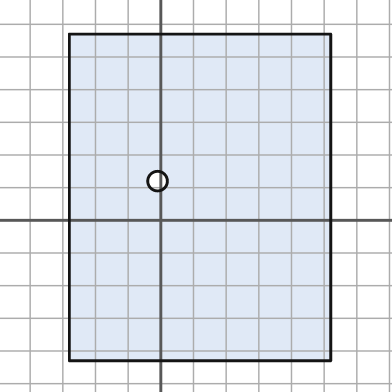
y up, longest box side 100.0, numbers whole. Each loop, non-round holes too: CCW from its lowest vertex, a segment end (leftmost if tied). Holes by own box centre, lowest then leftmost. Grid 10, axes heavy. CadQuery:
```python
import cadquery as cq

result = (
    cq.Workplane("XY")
    .moveTo(-28.0, -43.0)
    .lineTo(52.0, -43.0)
    .lineTo(52.0, 57.0)
    .lineTo(-28.0, 57.0)
    .close()
    .moveTo(-1.0, 12.0)
    .circle(3.0)
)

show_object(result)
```